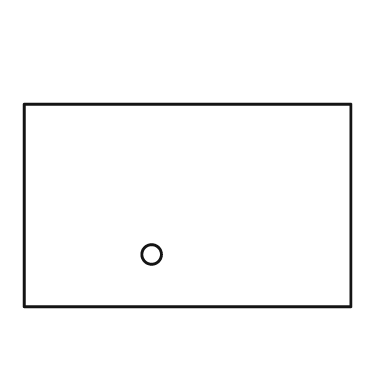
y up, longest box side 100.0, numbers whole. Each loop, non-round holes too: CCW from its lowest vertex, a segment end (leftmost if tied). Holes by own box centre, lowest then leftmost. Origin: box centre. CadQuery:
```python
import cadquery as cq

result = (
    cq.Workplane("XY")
    .moveTo(-50.0, -31.0)
    .lineTo(50.0, -31.0)
    .lineTo(50.0, 31.0)
    .lineTo(-50.0, 31.0)
    .close()
    .moveTo(-11.0, -15.0)
    .circle(3.0)
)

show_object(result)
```